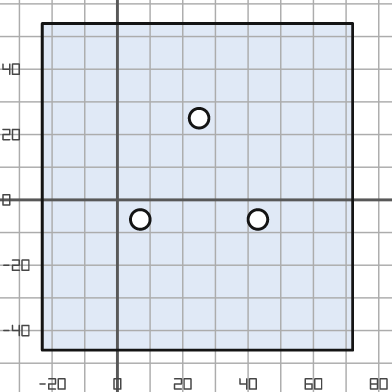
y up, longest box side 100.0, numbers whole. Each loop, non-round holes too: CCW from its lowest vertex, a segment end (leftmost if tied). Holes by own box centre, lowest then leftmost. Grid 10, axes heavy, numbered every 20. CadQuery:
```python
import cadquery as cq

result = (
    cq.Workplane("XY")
    .moveTo(-23.0, -46.0)
    .lineTo(72.0, -46.0)
    .lineTo(72.0, 54.0)
    .lineTo(-23.0, 54.0)
    .close()
    .moveTo(7.0, -6.0)
    .circle(3.0)
    .moveTo(43.0, -6.0)
    .circle(3.0)
    .moveTo(25.0, 25.0)
    .circle(3.0)
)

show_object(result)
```